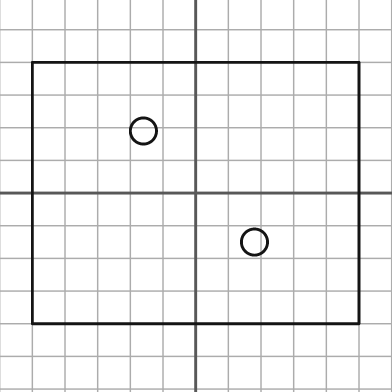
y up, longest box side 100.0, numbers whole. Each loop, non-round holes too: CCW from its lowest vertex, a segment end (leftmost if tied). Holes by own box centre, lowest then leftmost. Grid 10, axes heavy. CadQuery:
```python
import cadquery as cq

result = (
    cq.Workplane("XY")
    .moveTo(-50.0, -40.0)
    .lineTo(50.0, -40.0)
    .lineTo(50.0, 40.0)
    .lineTo(-50.0, 40.0)
    .close()
    .moveTo(18.0, -15.0)
    .circle(4.0)
    .moveTo(-16.0, 19.0)
    .circle(4.0)
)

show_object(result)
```